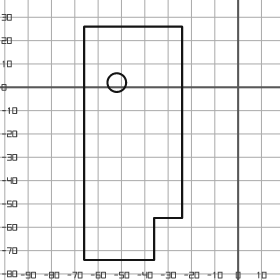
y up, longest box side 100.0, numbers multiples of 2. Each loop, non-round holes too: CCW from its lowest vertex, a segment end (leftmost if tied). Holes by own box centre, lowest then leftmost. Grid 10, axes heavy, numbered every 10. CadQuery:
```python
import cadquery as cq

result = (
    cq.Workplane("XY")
    .moveTo(-66.0, -74.0)
    .lineTo(-36.0, -74.0)
    .lineTo(-36.0, -56.0)
    .lineTo(-24.0, -56.0)
    .lineTo(-24.0, 26.0)
    .lineTo(-66.0, 26.0)
    .close()
    .moveTo(-52.0, 2.0)
    .circle(4.0)
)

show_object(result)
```